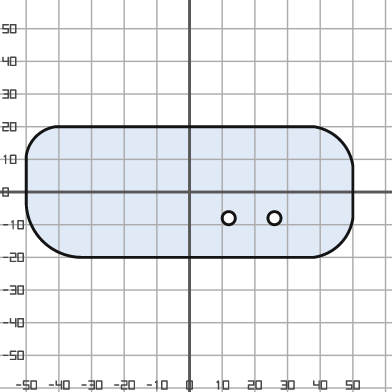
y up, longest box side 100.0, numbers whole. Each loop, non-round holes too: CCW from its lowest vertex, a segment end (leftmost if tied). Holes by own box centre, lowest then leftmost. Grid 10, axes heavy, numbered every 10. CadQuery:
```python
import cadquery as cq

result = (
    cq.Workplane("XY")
    .moveTo(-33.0, -20.0)
    .lineTo(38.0, -20.0)
    .threePointArc((46.0, -16.0), (50.0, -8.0))
    .lineTo(50.0, 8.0)
    .threePointArc((46.0, 16.0), (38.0, 20.0))
    .lineTo(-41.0, 20.0)
    .threePointArc((-47.0, 17.0), (-50.0, 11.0))
    .lineTo(-50.0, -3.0)
    .threePointArc((-45.0, -15.0), (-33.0, -20.0))
    .close()
    .moveTo(12.0, -8.0)
    .circle(2.0)
    .moveTo(26.0, -8.0)
    .circle(2.0)
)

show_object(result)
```